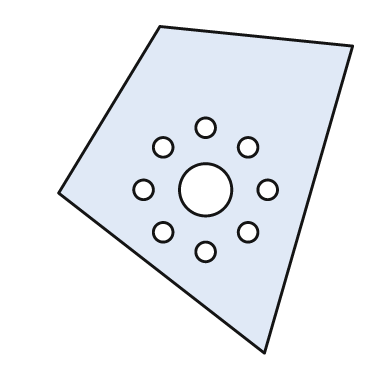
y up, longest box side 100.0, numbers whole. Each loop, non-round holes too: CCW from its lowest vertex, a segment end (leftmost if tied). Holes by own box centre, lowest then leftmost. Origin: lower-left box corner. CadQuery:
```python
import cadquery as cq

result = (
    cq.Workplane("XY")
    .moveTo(63.0, 0.0)
    .lineTo(90.0, 94.0)
    .lineTo(31.0, 100.0)
    .lineTo(0.0, 49.0)
    .close()
    .moveTo(45.0, 31.0)
    .circle(3.0)
    .moveTo(32.0, 37.0)
    .circle(3.0)
    .moveTo(58.0, 37.0)
    .circle(3.0)
    .moveTo(26.0, 50.0)
    .circle(3.0)
    .moveTo(45.0, 50.0)
    .circle(8.0)
    .moveTo(64.0, 50.0)
    .circle(3.0)
    .moveTo(32.0, 63.0)
    .circle(3.0)
    .moveTo(58.0, 63.0)
    .circle(3.0)
    .moveTo(45.0, 69.0)
    .circle(3.0)
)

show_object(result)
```